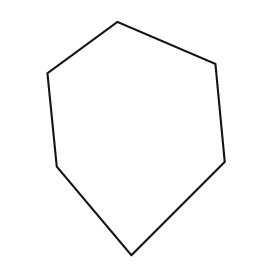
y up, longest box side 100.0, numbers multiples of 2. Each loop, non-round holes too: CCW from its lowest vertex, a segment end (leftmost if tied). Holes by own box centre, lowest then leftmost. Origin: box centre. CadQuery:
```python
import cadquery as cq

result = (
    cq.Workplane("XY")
    .moveTo(-2.0, -50.0)
    .lineTo(38.0, -10.0)
    .lineTo(34.0, 32.0)
    .lineTo(-8.0, 50.0)
    .lineTo(-38.0, 28.0)
    .lineTo(-34.0, -12.0)
    .close()
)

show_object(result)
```